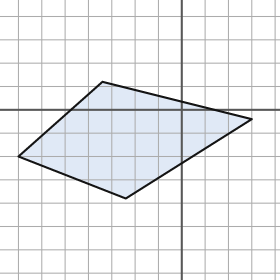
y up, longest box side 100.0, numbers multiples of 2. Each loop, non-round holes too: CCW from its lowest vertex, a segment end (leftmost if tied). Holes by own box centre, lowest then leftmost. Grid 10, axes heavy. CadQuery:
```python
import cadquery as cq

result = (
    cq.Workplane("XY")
    .moveTo(-24.0, -38.0)
    .lineTo(30.0, -4.0)
    .lineTo(-34.0, 12.0)
    .lineTo(-70.0, -20.0)
    .close()
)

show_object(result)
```